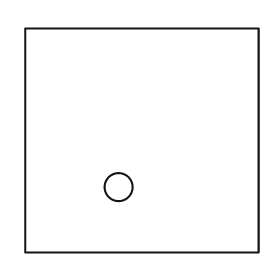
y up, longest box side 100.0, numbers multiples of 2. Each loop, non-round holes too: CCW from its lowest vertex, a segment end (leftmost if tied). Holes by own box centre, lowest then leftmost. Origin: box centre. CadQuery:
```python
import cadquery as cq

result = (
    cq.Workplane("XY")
    .moveTo(-50.0, -48.0)
    .lineTo(50.0, -48.0)
    .lineTo(50.0, 48.0)
    .lineTo(-50.0, 48.0)
    .close()
    .moveTo(-10.0, -20.0)
    .circle(6.0)
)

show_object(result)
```